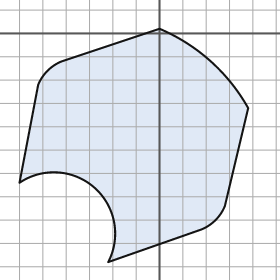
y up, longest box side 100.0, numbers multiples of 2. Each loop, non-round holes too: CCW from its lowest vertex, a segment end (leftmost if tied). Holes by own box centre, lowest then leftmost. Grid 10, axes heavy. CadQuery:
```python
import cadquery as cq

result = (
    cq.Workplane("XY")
    .moveTo(-22.0, -98.0)
    .lineTo(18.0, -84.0)
    .threePointArc((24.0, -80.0), (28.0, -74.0))
    .lineTo(38.0, -32.0)
    .threePointArc((22.0, -12.0), (0.0, 2.0))
    .lineTo(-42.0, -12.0)
    .threePointArc((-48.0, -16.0), (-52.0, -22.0))
    .lineTo(-60.0, -64.0)
    .threePointArc((-28.0, -66.0), (-22.0, -98.0))
    .close()
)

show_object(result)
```